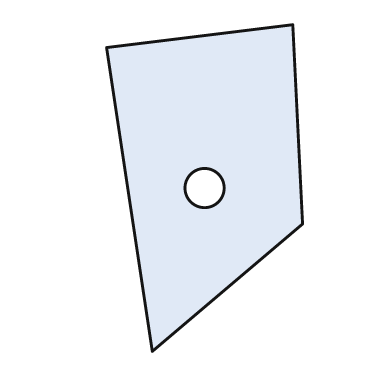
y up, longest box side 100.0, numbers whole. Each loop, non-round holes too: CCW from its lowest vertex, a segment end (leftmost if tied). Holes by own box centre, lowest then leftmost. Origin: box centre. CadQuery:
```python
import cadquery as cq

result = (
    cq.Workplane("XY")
    .moveTo(-16.0, -50.0)
    .lineTo(30.0, -11.0)
    .lineTo(27.0, 50.0)
    .lineTo(-30.0, 43.0)
    .close()
    .moveTo(0.0, 0.0)
    .circle(6.0)
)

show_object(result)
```